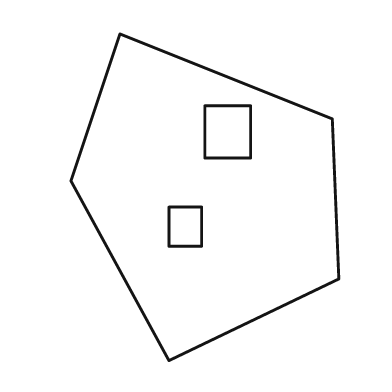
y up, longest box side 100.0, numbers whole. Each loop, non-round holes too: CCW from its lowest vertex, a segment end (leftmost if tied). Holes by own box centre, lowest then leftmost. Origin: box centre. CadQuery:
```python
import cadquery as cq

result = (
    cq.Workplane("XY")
    .moveTo(-11.0, -50.0)
    .lineTo(41.0, -25.0)
    .lineTo(39.0, 24.0)
    .lineTo(-26.0, 50.0)
    .lineTo(-41.0, 5.0)
    .close()
    .moveTo(-11.0, -15.0)
    .lineTo(-1.0, -15.0)
    .lineTo(-1.0, -3.0)
    .lineTo(-11.0, -3.0)
    .close()
    .moveTo(0.0, 12.0)
    .lineTo(14.0, 12.0)
    .lineTo(14.0, 28.0)
    .lineTo(0.0, 28.0)
    .close()
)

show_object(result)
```